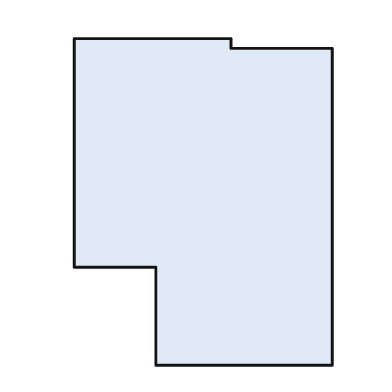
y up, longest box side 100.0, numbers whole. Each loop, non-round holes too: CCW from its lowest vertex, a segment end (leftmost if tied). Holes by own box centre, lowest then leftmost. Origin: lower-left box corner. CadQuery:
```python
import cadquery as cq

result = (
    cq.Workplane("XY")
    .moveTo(25.0, 0.0)
    .lineTo(79.0, 0.0)
    .lineTo(79.0, 97.0)
    .lineTo(48.0, 97.0)
    .lineTo(48.0, 100.0)
    .lineTo(0.0, 100.0)
    .lineTo(0.0, 30.0)
    .lineTo(25.0, 30.0)
    .close()
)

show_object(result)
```